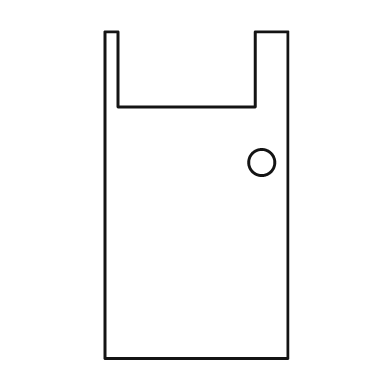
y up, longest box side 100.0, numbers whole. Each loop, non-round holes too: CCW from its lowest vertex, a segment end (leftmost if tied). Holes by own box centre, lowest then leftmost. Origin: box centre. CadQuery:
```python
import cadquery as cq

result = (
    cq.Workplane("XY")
    .moveTo(-28.0, -50.0)
    .lineTo(28.0, -50.0)
    .lineTo(28.0, 50.0)
    .lineTo(18.0, 50.0)
    .lineTo(18.0, 27.0)
    .lineTo(-24.0, 27.0)
    .lineTo(-24.0, 50.0)
    .lineTo(-28.0, 50.0)
    .close()
    .moveTo(20.0, 10.0)
    .circle(4.0)
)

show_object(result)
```